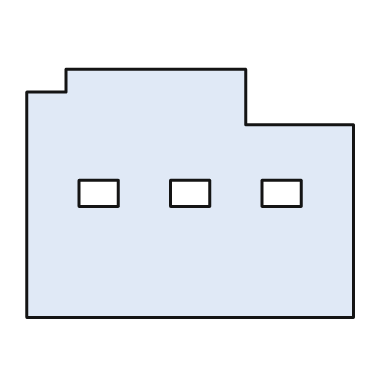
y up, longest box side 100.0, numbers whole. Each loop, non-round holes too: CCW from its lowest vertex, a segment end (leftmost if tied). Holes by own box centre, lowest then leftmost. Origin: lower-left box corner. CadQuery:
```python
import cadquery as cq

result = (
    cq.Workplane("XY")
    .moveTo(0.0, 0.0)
    .lineTo(100.0, 0.0)
    .lineTo(100.0, 59.0)
    .lineTo(67.0, 59.0)
    .lineTo(67.0, 76.0)
    .lineTo(12.0, 76.0)
    .lineTo(12.0, 69.0)
    .lineTo(0.0, 69.0)
    .close()
    .moveTo(16.0, 34.0)
    .lineTo(28.0, 34.0)
    .lineTo(28.0, 42.0)
    .lineTo(16.0, 42.0)
    .close()
    .moveTo(44.0, 34.0)
    .lineTo(56.0, 34.0)
    .lineTo(56.0, 42.0)
    .lineTo(44.0, 42.0)
    .close()
    .moveTo(72.0, 34.0)
    .lineTo(84.0, 34.0)
    .lineTo(84.0, 42.0)
    .lineTo(72.0, 42.0)
    .close()
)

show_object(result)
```